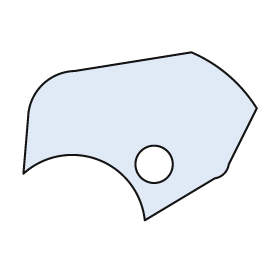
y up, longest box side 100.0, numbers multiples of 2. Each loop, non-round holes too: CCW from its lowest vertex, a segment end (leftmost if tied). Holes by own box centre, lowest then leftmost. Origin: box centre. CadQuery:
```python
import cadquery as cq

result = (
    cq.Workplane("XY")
    .moveTo(2.0, -36.0)
    .lineTo(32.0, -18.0)
    .threePointArc((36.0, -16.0), (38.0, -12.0))
    .lineTo(50.0, 12.0)
    .threePointArc((38.0, 26.0), (22.0, 36.0))
    .lineTo(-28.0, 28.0)
    .threePointArc((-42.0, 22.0), (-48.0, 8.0))
    .lineTo(-50.0, -16.0)
    .threePointArc((-18.0, -10.0), (2.0, -36.0))
    .close()
    .moveTo(6.0, -12.0)
    .circle(8.0)
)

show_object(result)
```